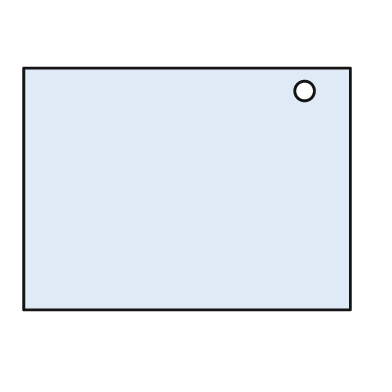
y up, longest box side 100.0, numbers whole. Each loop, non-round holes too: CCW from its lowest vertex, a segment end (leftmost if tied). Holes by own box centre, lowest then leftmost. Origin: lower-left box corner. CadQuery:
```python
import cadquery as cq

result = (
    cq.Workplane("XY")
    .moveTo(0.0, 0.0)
    .lineTo(100.0, 0.0)
    .lineTo(100.0, 74.0)
    .lineTo(0.0, 74.0)
    .close()
    .moveTo(86.0, 67.0)
    .circle(3.0)
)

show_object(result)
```